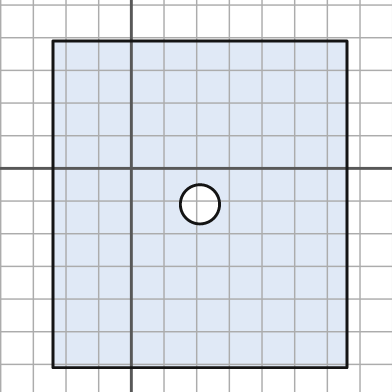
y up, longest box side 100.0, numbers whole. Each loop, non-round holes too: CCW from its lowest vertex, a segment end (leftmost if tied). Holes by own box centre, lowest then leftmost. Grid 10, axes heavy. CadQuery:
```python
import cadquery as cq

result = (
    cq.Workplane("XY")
    .moveTo(-24.0, -61.0)
    .lineTo(66.0, -61.0)
    .lineTo(66.0, 39.0)
    .lineTo(-24.0, 39.0)
    .close()
    .moveTo(21.0, -11.0)
    .circle(6.0)
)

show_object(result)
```